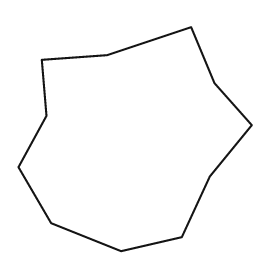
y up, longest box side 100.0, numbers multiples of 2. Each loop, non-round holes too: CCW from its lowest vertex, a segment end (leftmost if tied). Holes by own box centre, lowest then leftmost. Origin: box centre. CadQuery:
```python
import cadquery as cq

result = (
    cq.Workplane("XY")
    .moveTo(-6.0, -48.0)
    .lineTo(20.0, -42.0)
    .lineTo(32.0, -16.0)
    .lineTo(50.0, 6.0)
    .lineTo(34.0, 24.0)
    .lineTo(24.0, 48.0)
    .lineTo(-12.0, 36.0)
    .lineTo(-40.0, 34.0)
    .lineTo(-38.0, 10.0)
    .lineTo(-50.0, -12.0)
    .lineTo(-36.0, -36.0)
    .close()
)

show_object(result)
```